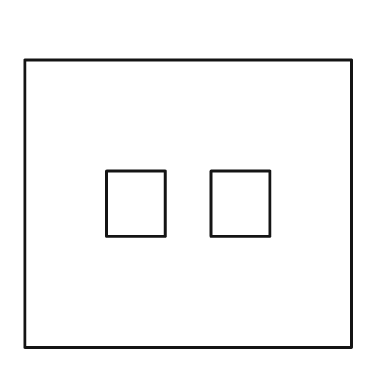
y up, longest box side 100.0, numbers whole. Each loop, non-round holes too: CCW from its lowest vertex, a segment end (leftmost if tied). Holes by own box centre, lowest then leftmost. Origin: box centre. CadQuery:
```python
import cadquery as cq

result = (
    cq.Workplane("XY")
    .moveTo(-50.0, -44.0)
    .lineTo(50.0, -44.0)
    .lineTo(50.0, 44.0)
    .lineTo(-50.0, 44.0)
    .close()
    .moveTo(-25.0, -10.0)
    .lineTo(-7.0, -10.0)
    .lineTo(-7.0, 10.0)
    .lineTo(-25.0, 10.0)
    .close()
    .moveTo(7.0, -10.0)
    .lineTo(25.0, -10.0)
    .lineTo(25.0, 10.0)
    .lineTo(7.0, 10.0)
    .close()
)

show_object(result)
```